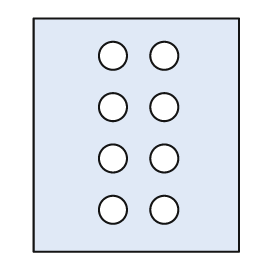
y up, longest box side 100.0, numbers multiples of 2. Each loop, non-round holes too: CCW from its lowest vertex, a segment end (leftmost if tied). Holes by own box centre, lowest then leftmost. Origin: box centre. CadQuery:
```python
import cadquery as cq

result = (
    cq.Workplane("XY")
    .moveTo(-44.0, -50.0)
    .lineTo(44.0, -50.0)
    .lineTo(44.0, 50.0)
    .lineTo(-44.0, 50.0)
    .close()
    .moveTo(-10.0, -32.0)
    .circle(6.0)
    .moveTo(12.0, -32.0)
    .circle(6.0)
    .moveTo(-10.0, -10.0)
    .circle(6.0)
    .moveTo(12.0, -10.0)
    .circle(6.0)
    .moveTo(-10.0, 12.0)
    .circle(6.0)
    .moveTo(12.0, 12.0)
    .circle(6.0)
    .moveTo(-10.0, 34.0)
    .circle(6.0)
    .moveTo(12.0, 34.0)
    .circle(6.0)
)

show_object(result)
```